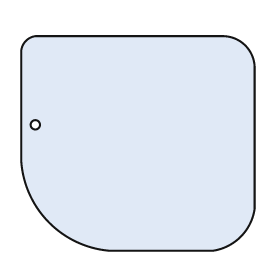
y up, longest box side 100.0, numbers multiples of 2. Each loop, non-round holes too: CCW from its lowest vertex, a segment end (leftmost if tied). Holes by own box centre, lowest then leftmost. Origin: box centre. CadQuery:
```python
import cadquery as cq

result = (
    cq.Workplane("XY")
    .moveTo(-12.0, -46.0)
    .lineTo(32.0, -46.0)
    .threePointArc((44.0, -40.0), (50.0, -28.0))
    .lineTo(50.0, 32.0)
    .threePointArc((46.0, 42.0), (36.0, 46.0))
    .lineTo(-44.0, 46.0)
    .threePointArc((-48.0, 44.0), (-50.0, 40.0))
    .lineTo(-50.0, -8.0)
    .threePointArc((-38.0, -34.0), (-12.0, -46.0))
    .close()
    .moveTo(-44.0, 8.0)
    .circle(2.0)
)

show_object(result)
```